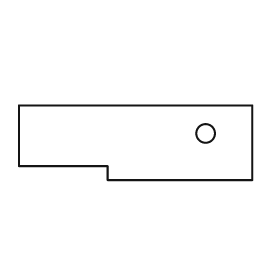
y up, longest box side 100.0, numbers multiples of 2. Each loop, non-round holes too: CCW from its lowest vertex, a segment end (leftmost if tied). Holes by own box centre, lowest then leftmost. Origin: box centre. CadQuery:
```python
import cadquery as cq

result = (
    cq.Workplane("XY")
    .moveTo(-12.0, -16.0)
    .lineTo(50.0, -16.0)
    .lineTo(50.0, 16.0)
    .lineTo(-50.0, 16.0)
    .lineTo(-50.0, -10.0)
    .lineTo(-12.0, -10.0)
    .close()
    .moveTo(30.0, 4.0)
    .circle(4.0)
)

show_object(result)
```